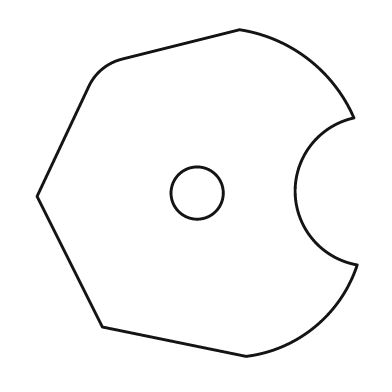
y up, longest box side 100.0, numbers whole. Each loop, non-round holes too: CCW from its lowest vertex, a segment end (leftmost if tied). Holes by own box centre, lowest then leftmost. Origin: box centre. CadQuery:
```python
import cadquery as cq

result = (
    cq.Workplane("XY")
    .moveTo(15.0, -50.0)
    .threePointArc((36.0, -41.0), (49.0, -22.0))
    .threePointArc((30.0, 0.0), (48.0, 23.0))
    .threePointArc((34.0, 41.0), (13.0, 50.0))
    .lineTo(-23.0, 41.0)
    .threePointArc((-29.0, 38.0), (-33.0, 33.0))
    .lineTo(-49.0, -1.0)
    .lineTo(-29.0, -41.0)
    .close()
    .moveTo(0.0, 0.0)
    .circle(8.0)
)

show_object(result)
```